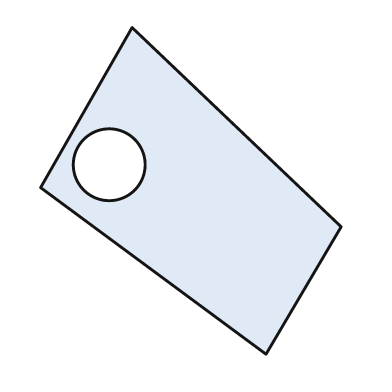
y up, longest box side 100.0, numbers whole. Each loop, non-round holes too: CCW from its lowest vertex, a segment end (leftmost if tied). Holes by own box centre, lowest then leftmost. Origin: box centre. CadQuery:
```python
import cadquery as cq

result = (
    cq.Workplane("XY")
    .moveTo(23.0, -50.0)
    .lineTo(46.0, -11.0)
    .lineTo(-18.0, 50.0)
    .lineTo(-46.0, 1.0)
    .close()
    .moveTo(-25.0, 8.0)
    .circle(11.0)
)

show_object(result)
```